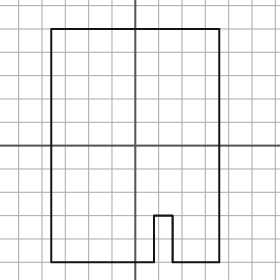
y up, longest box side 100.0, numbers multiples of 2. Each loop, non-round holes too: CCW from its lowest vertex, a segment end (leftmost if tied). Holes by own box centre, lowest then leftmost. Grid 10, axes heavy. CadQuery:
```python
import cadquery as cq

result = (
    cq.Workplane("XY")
    .moveTo(-36.0, -50.0)
    .lineTo(8.0, -50.0)
    .lineTo(8.0, -30.0)
    .lineTo(16.0, -30.0)
    .lineTo(16.0, -50.0)
    .lineTo(36.0, -50.0)
    .lineTo(36.0, 50.0)
    .lineTo(-36.0, 50.0)
    .close()
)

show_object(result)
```